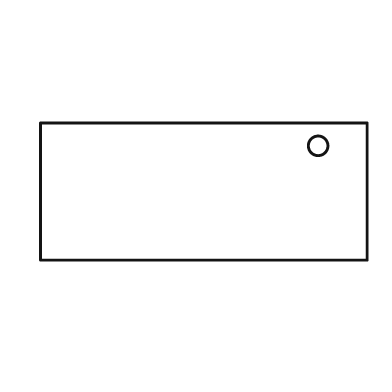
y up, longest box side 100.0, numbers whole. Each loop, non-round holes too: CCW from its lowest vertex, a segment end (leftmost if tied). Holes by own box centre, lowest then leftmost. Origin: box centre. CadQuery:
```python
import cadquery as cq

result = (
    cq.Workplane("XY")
    .moveTo(-50.0, -21.0)
    .lineTo(50.0, -21.0)
    .lineTo(50.0, 21.0)
    .lineTo(-50.0, 21.0)
    .close()
    .moveTo(35.0, 14.0)
    .circle(3.0)
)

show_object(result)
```